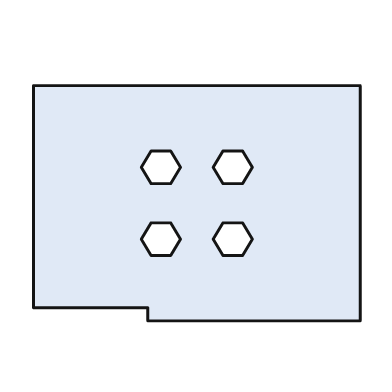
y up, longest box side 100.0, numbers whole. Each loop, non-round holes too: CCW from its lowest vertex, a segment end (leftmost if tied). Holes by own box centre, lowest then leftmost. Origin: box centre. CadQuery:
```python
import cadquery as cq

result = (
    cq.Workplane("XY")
    .moveTo(-15.0, -36.0)
    .lineTo(50.0, -36.0)
    .lineTo(50.0, 36.0)
    .lineTo(-50.0, 36.0)
    .lineTo(-50.0, -32.0)
    .lineTo(-15.0, -32.0)
    .close()
    .moveTo(-14.0, -16.0)
    .lineTo(-8.0, -16.0)
    .lineTo(-5.0, -11.0)
    .lineTo(-8.0, -6.0)
    .lineTo(-14.0, -6.0)
    .lineTo(-17.0, -11.0)
    .close()
    .moveTo(8.0, -16.0)
    .lineTo(14.0, -16.0)
    .lineTo(17.0, -11.0)
    .lineTo(14.0, -6.0)
    .lineTo(8.0, -6.0)
    .lineTo(5.0, -11.0)
    .close()
    .moveTo(-14.0, 6.0)
    .lineTo(-8.0, 6.0)
    .lineTo(-5.0, 11.0)
    .lineTo(-8.0, 16.0)
    .lineTo(-14.0, 16.0)
    .lineTo(-17.0, 11.0)
    .close()
    .moveTo(8.0, 6.0)
    .lineTo(14.0, 6.0)
    .lineTo(17.0, 11.0)
    .lineTo(14.0, 16.0)
    .lineTo(8.0, 16.0)
    .lineTo(5.0, 11.0)
    .close()
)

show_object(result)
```